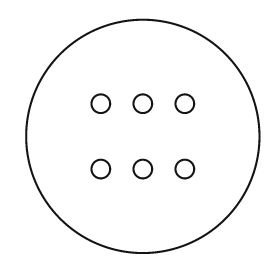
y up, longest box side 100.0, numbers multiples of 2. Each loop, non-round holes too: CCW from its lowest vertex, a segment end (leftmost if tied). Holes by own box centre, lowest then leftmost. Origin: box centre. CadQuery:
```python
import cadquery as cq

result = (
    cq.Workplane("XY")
    .moveTo(0.0, 0.0)
    .circle(50.0)
    .moveTo(-18.0, -14.0)
    .circle(4.0)
    .moveTo(0.0, -14.0)
    .circle(4.0)
    .moveTo(18.0, -14.0)
    .circle(4.0)
    .moveTo(-18.0, 14.0)
    .circle(4.0)
    .moveTo(0.0, 14.0)
    .circle(4.0)
    .moveTo(18.0, 14.0)
    .circle(4.0)
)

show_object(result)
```